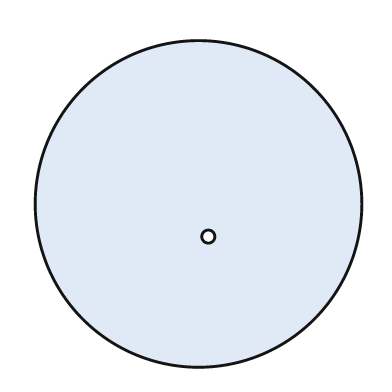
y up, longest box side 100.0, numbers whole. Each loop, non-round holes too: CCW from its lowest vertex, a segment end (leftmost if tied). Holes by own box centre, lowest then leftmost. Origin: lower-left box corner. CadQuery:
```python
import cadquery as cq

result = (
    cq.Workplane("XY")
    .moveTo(50.0, 50.0)
    .circle(50.0)
    .moveTo(53.0, 40.0)
    .circle(2.0)
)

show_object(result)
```